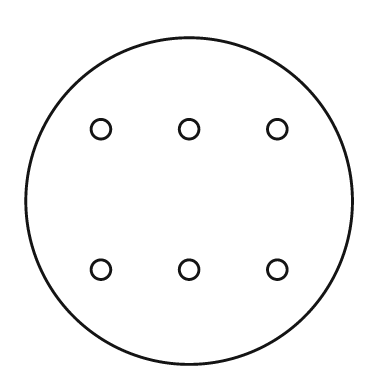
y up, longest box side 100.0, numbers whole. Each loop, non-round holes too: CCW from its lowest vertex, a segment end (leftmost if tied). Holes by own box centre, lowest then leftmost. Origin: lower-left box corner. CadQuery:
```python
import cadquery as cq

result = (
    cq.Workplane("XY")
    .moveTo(50.0, 50.0)
    .circle(50.0)
    .moveTo(23.0, 29.0)
    .circle(3.0)
    .moveTo(50.0, 29.0)
    .circle(3.0)
    .moveTo(77.0, 29.0)
    .circle(3.0)
    .moveTo(23.0, 72.0)
    .circle(3.0)
    .moveTo(50.0, 72.0)
    .circle(3.0)
    .moveTo(77.0, 72.0)
    .circle(3.0)
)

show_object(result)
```